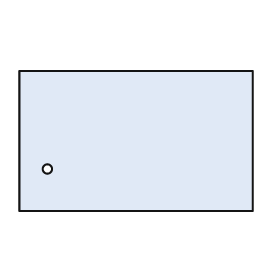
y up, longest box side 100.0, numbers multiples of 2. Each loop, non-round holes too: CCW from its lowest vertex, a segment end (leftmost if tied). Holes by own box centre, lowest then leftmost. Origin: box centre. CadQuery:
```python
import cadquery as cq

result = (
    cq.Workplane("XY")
    .moveTo(-50.0, -30.0)
    .lineTo(50.0, -30.0)
    .lineTo(50.0, 30.0)
    .lineTo(-50.0, 30.0)
    .close()
    .moveTo(-38.0, -12.0)
    .circle(2.0)
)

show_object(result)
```